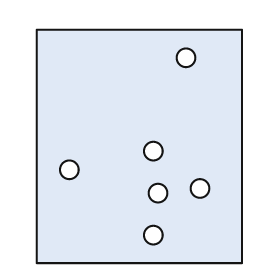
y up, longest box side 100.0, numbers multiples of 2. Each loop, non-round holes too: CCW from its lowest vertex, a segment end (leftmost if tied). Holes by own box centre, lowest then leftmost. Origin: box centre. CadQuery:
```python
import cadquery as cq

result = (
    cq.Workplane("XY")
    .moveTo(-44.0, -50.0)
    .lineTo(44.0, -50.0)
    .lineTo(44.0, 50.0)
    .lineTo(-44.0, 50.0)
    .close()
    .moveTo(6.0, -38.0)
    .circle(4.0)
    .moveTo(8.0, -20.0)
    .circle(4.0)
    .moveTo(26.0, -18.0)
    .circle(4.0)
    .moveTo(-30.0, -10.0)
    .circle(4.0)
    .moveTo(6.0, -2.0)
    .circle(4.0)
    .moveTo(20.0, 38.0)
    .circle(4.0)
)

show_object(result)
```